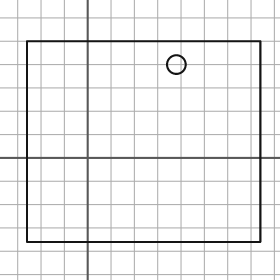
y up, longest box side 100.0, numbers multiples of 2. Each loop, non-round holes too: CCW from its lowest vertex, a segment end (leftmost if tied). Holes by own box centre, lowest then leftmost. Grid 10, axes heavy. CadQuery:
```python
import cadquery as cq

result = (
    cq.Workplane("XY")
    .moveTo(-26.0, -36.0)
    .lineTo(74.0, -36.0)
    .lineTo(74.0, 50.0)
    .lineTo(-26.0, 50.0)
    .close()
    .moveTo(38.0, 40.0)
    .circle(4.0)
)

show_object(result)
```